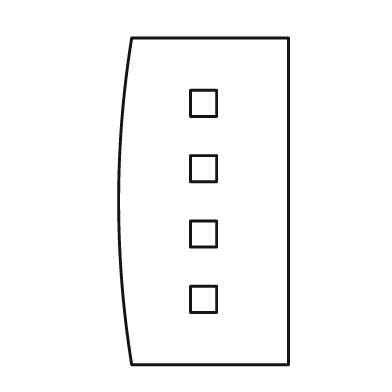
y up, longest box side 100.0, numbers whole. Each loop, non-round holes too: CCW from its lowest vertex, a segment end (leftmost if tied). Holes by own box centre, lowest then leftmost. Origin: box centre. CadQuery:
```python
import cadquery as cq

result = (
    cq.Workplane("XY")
    .moveTo(-22.0, -50.0)
    .lineTo(26.0, -50.0)
    .lineTo(26.0, 50.0)
    .lineTo(-22.0, 50.0)
    .threePointArc((-26.0, 0.0), (-22.0, -50.0))
    .close()
    .moveTo(-4.0, -34.0)
    .lineTo(4.0, -34.0)
    .lineTo(4.0, -26.0)
    .lineTo(-4.0, -26.0)
    .close()
    .moveTo(-4.0, -14.0)
    .lineTo(4.0, -14.0)
    .lineTo(4.0, -6.0)
    .lineTo(-4.0, -6.0)
    .close()
    .moveTo(-4.0, 6.0)
    .lineTo(4.0, 6.0)
    .lineTo(4.0, 14.0)
    .lineTo(-4.0, 14.0)
    .close()
    .moveTo(-4.0, 26.0)
    .lineTo(4.0, 26.0)
    .lineTo(4.0, 34.0)
    .lineTo(-4.0, 34.0)
    .close()
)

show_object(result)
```